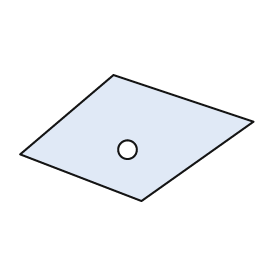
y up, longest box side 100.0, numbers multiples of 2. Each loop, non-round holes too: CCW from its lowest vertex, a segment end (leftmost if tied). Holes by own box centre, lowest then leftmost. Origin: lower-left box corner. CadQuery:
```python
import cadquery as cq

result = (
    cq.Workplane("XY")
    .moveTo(52.0, 0.0)
    .lineTo(100.0, 34.0)
    .lineTo(40.0, 54.0)
    .lineTo(0.0, 20.0)
    .close()
    .moveTo(46.0, 22.0)
    .circle(4.0)
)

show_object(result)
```